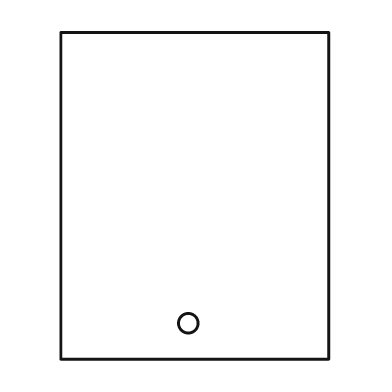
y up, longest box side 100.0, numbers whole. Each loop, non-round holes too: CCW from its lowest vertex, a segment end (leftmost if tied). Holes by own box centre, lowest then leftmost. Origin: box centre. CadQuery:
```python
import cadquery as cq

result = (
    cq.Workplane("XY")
    .moveTo(-41.0, -50.0)
    .lineTo(41.0, -50.0)
    .lineTo(41.0, 50.0)
    .lineTo(-41.0, 50.0)
    .close()
    .moveTo(-2.0, -39.0)
    .circle(3.0)
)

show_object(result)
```